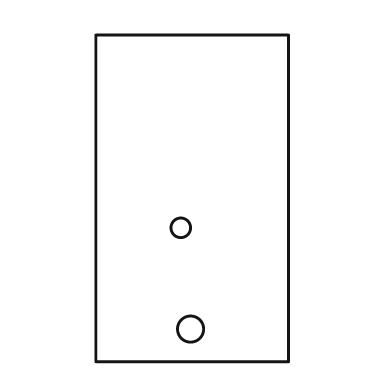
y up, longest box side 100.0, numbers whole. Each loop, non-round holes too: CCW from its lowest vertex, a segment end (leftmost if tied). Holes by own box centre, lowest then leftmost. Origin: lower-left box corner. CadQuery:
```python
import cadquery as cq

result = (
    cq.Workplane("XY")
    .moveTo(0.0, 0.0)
    .lineTo(59.0, 0.0)
    .lineTo(59.0, 100.0)
    .lineTo(0.0, 100.0)
    .close()
    .moveTo(29.0, 10.0)
    .circle(4.0)
    .moveTo(26.0, 41.0)
    .circle(3.0)
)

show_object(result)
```